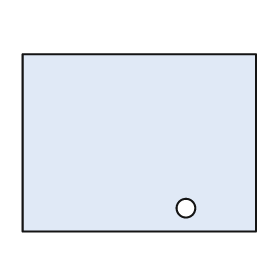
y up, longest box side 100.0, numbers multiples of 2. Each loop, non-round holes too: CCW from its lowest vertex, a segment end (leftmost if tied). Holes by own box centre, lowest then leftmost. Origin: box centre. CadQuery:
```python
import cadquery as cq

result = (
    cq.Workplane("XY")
    .moveTo(-50.0, -38.0)
    .lineTo(50.0, -38.0)
    .lineTo(50.0, 38.0)
    .lineTo(-50.0, 38.0)
    .close()
    .moveTo(20.0, -28.0)
    .circle(4.0)
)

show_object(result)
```